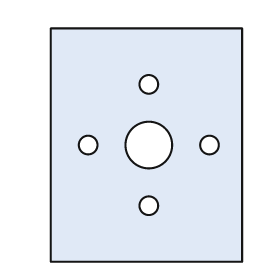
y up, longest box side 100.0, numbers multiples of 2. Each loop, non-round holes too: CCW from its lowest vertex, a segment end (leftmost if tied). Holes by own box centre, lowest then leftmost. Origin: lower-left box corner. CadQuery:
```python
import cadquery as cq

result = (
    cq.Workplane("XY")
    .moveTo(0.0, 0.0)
    .lineTo(82.0, 0.0)
    .lineTo(82.0, 100.0)
    .lineTo(0.0, 100.0)
    .close()
    .moveTo(42.0, 24.0)
    .circle(4.0)
    .moveTo(16.0, 50.0)
    .circle(4.0)
    .moveTo(42.0, 50.0)
    .circle(10.0)
    .moveTo(68.0, 50.0)
    .circle(4.0)
    .moveTo(42.0, 76.0)
    .circle(4.0)
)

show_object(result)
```